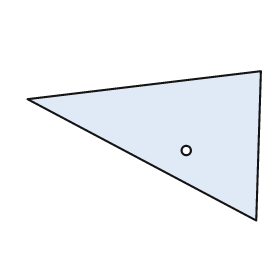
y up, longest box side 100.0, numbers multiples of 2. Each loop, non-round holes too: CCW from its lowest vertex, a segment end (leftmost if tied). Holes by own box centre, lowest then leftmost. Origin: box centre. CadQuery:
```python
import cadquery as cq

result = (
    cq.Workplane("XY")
    .moveTo(48.0, -32.0)
    .lineTo(50.0, 32.0)
    .lineTo(-50.0, 20.0)
    .close()
    .moveTo(18.0, -2.0)
    .circle(2.0)
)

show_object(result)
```